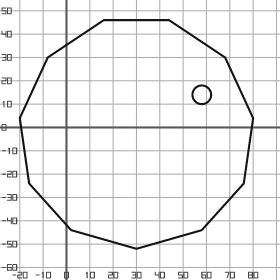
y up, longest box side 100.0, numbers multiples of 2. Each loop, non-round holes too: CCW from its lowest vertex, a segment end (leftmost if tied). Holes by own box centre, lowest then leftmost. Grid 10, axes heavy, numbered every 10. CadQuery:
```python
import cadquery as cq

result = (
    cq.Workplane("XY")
    .moveTo(30.0, -52.0)
    .lineTo(58.0, -44.0)
    .lineTo(76.0, -24.0)
    .lineTo(80.0, 4.0)
    .lineTo(68.0, 30.0)
    .lineTo(44.0, 46.0)
    .lineTo(16.0, 46.0)
    .lineTo(-8.0, 30.0)
    .lineTo(-20.0, 4.0)
    .lineTo(-16.0, -24.0)
    .lineTo(2.0, -44.0)
    .close()
    .moveTo(58.0, 14.0)
    .circle(4.0)
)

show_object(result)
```